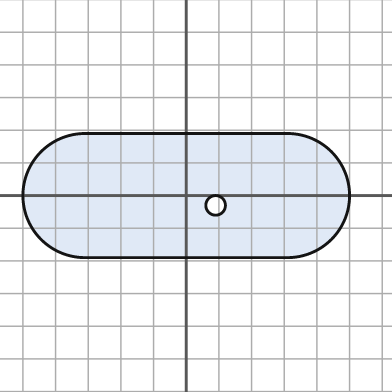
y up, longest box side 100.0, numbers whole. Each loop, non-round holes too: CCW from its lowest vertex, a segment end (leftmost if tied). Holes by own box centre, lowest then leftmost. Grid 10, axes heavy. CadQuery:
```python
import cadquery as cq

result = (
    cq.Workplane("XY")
    .moveTo(-31.0, -19.0)
    .lineTo(31.0, -19.0)
    .threePointArc((50.0, 0.0), (31.0, 19.0))
    .lineTo(-31.0, 19.0)
    .threePointArc((-50.0, 0.0), (-31.0, -19.0))
    .close()
    .moveTo(9.0, -3.0)
    .circle(3.0)
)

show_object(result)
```